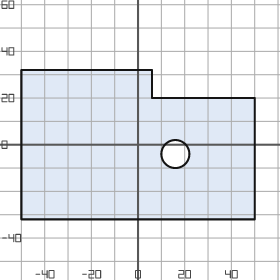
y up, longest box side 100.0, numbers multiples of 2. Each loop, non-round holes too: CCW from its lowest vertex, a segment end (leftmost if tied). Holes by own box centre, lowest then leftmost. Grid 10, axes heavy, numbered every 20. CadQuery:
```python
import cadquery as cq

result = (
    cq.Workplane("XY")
    .moveTo(-50.0, -32.0)
    .lineTo(50.0, -32.0)
    .lineTo(50.0, 20.0)
    .lineTo(6.0, 20.0)
    .lineTo(6.0, 32.0)
    .lineTo(-50.0, 32.0)
    .close()
    .moveTo(16.0, -4.0)
    .circle(6.0)
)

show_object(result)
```